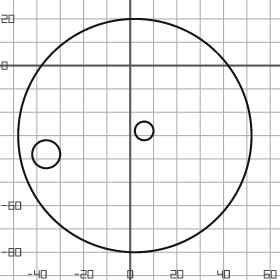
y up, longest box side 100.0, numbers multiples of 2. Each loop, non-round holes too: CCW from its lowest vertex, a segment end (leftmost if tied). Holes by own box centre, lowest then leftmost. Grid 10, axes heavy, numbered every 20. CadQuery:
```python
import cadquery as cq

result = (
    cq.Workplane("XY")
    .moveTo(2.0, -30.0)
    .circle(50.0)
    .moveTo(-36.0, -38.0)
    .circle(6.0)
    .moveTo(6.0, -28.0)
    .circle(4.0)
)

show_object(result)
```